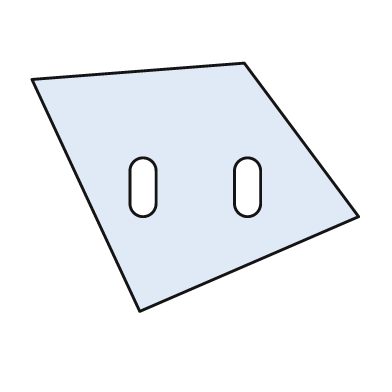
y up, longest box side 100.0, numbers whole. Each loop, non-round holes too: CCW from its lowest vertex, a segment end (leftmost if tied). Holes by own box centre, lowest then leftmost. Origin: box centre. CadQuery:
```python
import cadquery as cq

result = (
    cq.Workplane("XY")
    .moveTo(-17.0, -38.0)
    .lineTo(50.0, -9.0)
    .lineTo(15.0, 38.0)
    .lineTo(-50.0, 33.0)
    .close()
    .moveTo(-20.0, -5.0)
    .threePointArc((-16.0, -9.0), (-12.0, -5.0))
    .lineTo(-12.0, 5.0)
    .threePointArc((-16.0, 9.0), (-20.0, 5.0))
    .close()
    .moveTo(12.0, -5.0)
    .threePointArc((16.0, -9.0), (20.0, -5.0))
    .lineTo(20.0, 5.0)
    .threePointArc((16.0, 9.0), (12.0, 5.0))
    .close()
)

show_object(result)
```